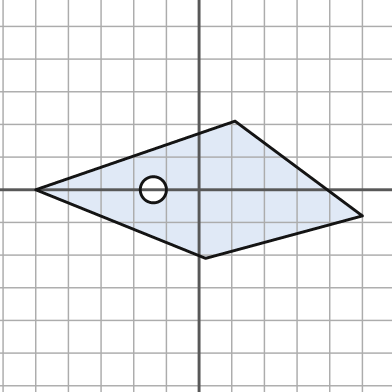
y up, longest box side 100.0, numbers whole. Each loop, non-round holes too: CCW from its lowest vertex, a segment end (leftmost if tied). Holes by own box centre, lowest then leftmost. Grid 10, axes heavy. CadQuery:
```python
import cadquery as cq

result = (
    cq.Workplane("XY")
    .moveTo(2.0, -21.0)
    .lineTo(50.0, -8.0)
    .lineTo(11.0, 21.0)
    .lineTo(-50.0, 0.0)
    .close()
    .moveTo(-14.0, 0.0)
    .circle(4.0)
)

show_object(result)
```